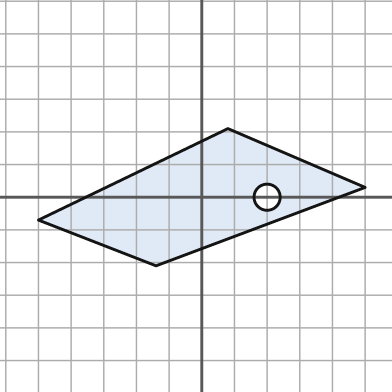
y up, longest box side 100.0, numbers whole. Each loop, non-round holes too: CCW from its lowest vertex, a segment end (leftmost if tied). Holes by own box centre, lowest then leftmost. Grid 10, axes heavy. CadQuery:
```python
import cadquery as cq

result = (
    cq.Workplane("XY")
    .moveTo(-14.0, -21.0)
    .lineTo(50.0, 3.0)
    .lineTo(8.0, 21.0)
    .lineTo(-50.0, -7.0)
    .close()
    .moveTo(20.0, 0.0)
    .circle(4.0)
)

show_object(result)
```